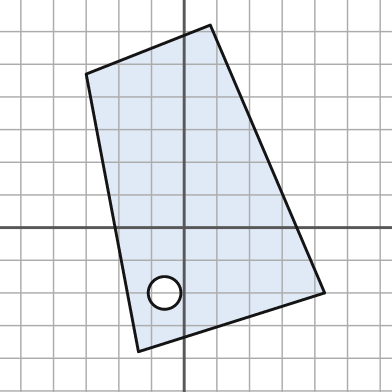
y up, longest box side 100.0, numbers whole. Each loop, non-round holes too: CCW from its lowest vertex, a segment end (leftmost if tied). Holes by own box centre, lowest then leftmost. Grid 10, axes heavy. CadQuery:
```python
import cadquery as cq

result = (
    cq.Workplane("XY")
    .moveTo(-14.0, -38.0)
    .lineTo(43.0, -20.0)
    .lineTo(8.0, 62.0)
    .lineTo(-30.0, 47.0)
    .close()
    .moveTo(-6.0, -20.0)
    .circle(5.0)
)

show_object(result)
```